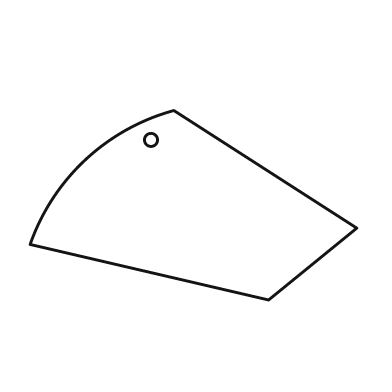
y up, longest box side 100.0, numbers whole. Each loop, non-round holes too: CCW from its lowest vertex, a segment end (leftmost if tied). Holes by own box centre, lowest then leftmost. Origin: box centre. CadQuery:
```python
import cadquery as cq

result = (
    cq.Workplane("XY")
    .moveTo(23.0, -29.0)
    .lineTo(50.0, -7.0)
    .lineTo(-6.0, 29.0)
    .threePointArc((-33.0, 14.0), (-50.0, -12.0))
    .close()
    .moveTo(-13.0, 20.0)
    .circle(2.0)
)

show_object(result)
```